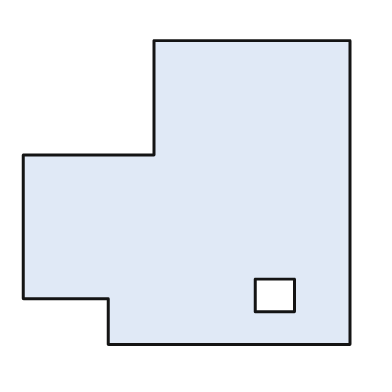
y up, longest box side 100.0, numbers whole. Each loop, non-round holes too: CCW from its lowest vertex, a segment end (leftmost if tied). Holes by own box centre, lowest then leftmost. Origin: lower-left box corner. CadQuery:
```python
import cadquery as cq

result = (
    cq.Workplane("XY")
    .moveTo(26.0, 0.0)
    .lineTo(100.0, 0.0)
    .lineTo(100.0, 93.0)
    .lineTo(40.0, 93.0)
    .lineTo(40.0, 58.0)
    .lineTo(0.0, 58.0)
    .lineTo(0.0, 14.0)
    .lineTo(26.0, 14.0)
    .close()
    .moveTo(71.0, 10.0)
    .lineTo(83.0, 10.0)
    .lineTo(83.0, 20.0)
    .lineTo(71.0, 20.0)
    .close()
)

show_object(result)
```